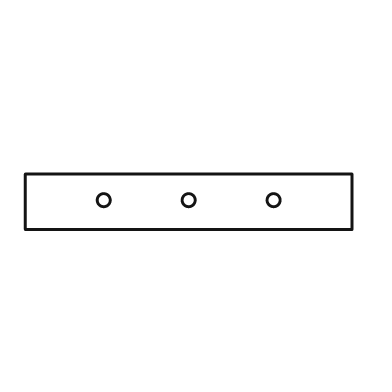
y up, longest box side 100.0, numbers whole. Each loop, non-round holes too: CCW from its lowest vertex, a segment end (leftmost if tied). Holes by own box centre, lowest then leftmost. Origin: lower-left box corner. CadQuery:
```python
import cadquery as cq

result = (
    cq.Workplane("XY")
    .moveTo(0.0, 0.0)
    .lineTo(100.0, 0.0)
    .lineTo(100.0, 17.0)
    .lineTo(0.0, 17.0)
    .close()
    .moveTo(24.0, 9.0)
    .circle(2.0)
    .moveTo(50.0, 9.0)
    .circle(2.0)
    .moveTo(76.0, 9.0)
    .circle(2.0)
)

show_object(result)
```